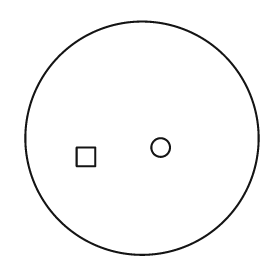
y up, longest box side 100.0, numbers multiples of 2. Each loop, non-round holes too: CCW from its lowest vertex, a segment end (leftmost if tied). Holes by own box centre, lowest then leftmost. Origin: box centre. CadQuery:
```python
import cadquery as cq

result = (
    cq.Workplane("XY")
    .moveTo(0.0, 0.0)
    .circle(50.0)
    .moveTo(-28.0, -12.0)
    .lineTo(-20.0, -12.0)
    .lineTo(-20.0, -4.0)
    .lineTo(-28.0, -4.0)
    .close()
    .moveTo(8.0, -4.0)
    .circle(4.0)
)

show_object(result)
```